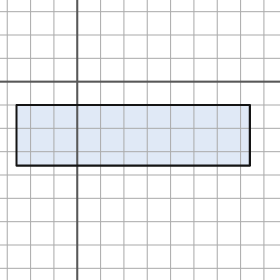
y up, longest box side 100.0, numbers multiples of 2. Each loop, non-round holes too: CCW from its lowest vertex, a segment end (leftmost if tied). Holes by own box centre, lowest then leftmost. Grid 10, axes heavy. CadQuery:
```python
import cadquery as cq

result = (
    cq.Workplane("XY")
    .moveTo(-26.0, -36.0)
    .lineTo(74.0, -36.0)
    .lineTo(74.0, -10.0)
    .lineTo(-26.0, -10.0)
    .close()
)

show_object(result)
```